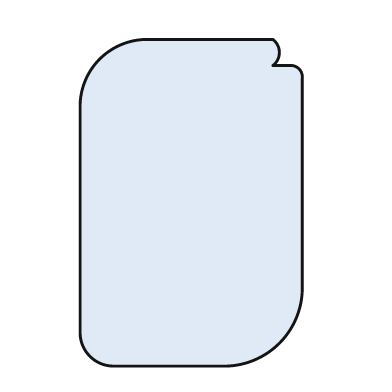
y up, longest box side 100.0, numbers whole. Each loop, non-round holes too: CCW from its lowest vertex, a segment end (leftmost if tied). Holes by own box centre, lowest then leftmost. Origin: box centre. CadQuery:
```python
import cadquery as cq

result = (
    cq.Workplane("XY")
    .moveTo(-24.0, -50.0)
    .lineTo(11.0, -50.0)
    .threePointArc((27.0, -43.0), (34.0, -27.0))
    .lineTo(34.0, 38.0)
    .threePointArc((33.0, 41.0), (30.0, 42.0))
    .lineTo(25.0, 42.0)
    .threePointArc((27.0, 46.0), (25.0, 50.0))
    .lineTo(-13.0, 50.0)
    .threePointArc((-28.0, 44.0), (-34.0, 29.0))
    .lineTo(-34.0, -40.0)
    .threePointArc((-31.0, -47.0), (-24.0, -50.0))
    .close()
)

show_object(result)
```